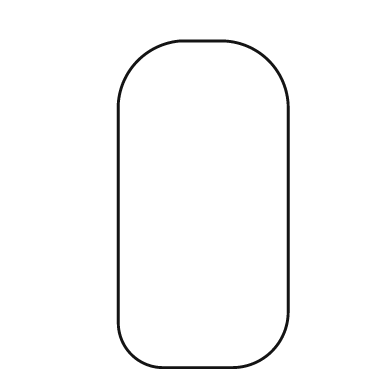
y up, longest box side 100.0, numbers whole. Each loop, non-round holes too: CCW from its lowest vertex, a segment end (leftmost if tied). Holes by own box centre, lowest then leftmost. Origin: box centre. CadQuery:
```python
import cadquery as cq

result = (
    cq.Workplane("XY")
    .moveTo(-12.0, -50.0)
    .lineTo(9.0, -50.0)
    .threePointArc((21.0, -45.0), (26.0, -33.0))
    .lineTo(26.0, 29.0)
    .threePointArc((20.0, 44.0), (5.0, 50.0))
    .lineTo(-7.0, 50.0)
    .threePointArc((-20.0, 44.0), (-26.0, 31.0))
    .lineTo(-26.0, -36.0)
    .threePointArc((-22.0, -46.0), (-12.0, -50.0))
    .close()
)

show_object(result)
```